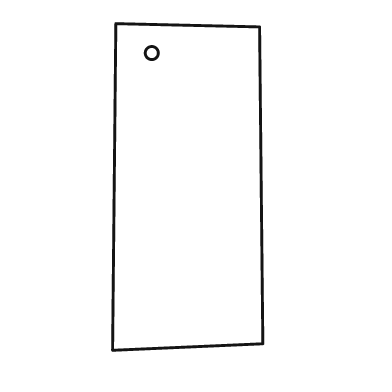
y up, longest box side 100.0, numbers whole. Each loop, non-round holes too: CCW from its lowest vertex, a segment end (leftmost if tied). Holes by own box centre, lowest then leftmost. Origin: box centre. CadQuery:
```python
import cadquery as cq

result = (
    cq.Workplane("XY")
    .moveTo(-23.0, -50.0)
    .lineTo(23.0, -48.0)
    .lineTo(22.0, 49.0)
    .lineTo(-22.0, 50.0)
    .close()
    .moveTo(-11.0, 41.0)
    .circle(2.0)
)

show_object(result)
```